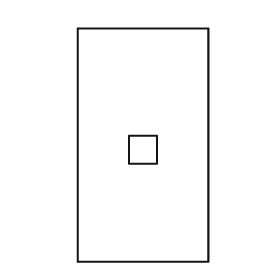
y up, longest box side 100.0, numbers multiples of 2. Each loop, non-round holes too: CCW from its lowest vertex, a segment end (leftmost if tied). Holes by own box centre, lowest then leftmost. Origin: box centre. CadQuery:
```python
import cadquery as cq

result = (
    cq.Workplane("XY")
    .moveTo(-28.0, -50.0)
    .lineTo(28.0, -50.0)
    .lineTo(28.0, 50.0)
    .lineTo(-28.0, 50.0)
    .close()
    .moveTo(-6.0, -8.0)
    .lineTo(6.0, -8.0)
    .lineTo(6.0, 4.0)
    .lineTo(-6.0, 4.0)
    .close()
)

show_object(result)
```